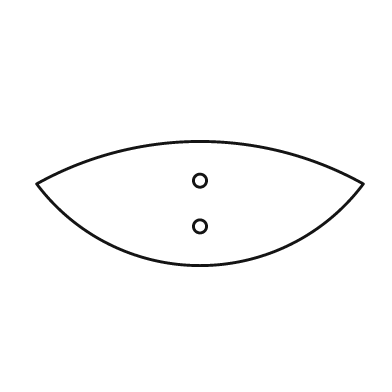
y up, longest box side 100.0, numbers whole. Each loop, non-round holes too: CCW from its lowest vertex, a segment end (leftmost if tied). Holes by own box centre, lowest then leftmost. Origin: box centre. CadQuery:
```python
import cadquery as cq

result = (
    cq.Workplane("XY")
    .moveTo(-50.0, 6.0)
    .threePointArc((0.0, -19.0), (50.0, 6.0))
    .threePointArc((0.0, 19.0), (-50.0, 6.0))
    .close()
    .moveTo(0.0, -7.0)
    .circle(2.0)
    .moveTo(0.0, 7.0)
    .circle(2.0)
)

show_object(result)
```